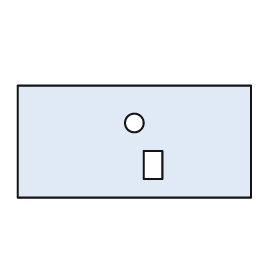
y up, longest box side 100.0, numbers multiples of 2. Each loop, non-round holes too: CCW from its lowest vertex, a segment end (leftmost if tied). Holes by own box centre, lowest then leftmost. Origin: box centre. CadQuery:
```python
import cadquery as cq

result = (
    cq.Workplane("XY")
    .moveTo(-50.0, -24.0)
    .lineTo(50.0, -24.0)
    .lineTo(50.0, 24.0)
    .lineTo(-50.0, 24.0)
    .close()
    .moveTo(4.0, -16.0)
    .lineTo(12.0, -16.0)
    .lineTo(12.0, -4.0)
    .lineTo(4.0, -4.0)
    .close()
    .moveTo(0.0, 8.0)
    .circle(4.0)
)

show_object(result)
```